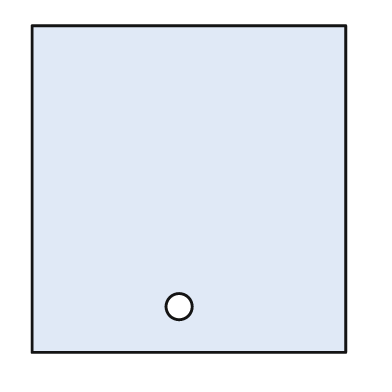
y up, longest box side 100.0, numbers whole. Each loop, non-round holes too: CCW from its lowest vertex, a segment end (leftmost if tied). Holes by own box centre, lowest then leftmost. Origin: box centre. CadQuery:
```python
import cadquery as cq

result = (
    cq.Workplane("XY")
    .moveTo(-48.0, -50.0)
    .lineTo(48.0, -50.0)
    .lineTo(48.0, 50.0)
    .lineTo(-48.0, 50.0)
    .close()
    .moveTo(-3.0, -36.0)
    .circle(4.0)
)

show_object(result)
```